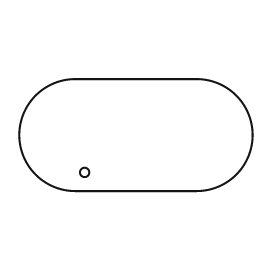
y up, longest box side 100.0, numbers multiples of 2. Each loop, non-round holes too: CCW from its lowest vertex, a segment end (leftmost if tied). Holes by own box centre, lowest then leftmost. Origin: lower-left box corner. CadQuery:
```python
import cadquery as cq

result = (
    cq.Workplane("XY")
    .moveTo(24.0, 0.0)
    .lineTo(76.0, 0.0)
    .threePointArc((100.0, 24.0), (76.0, 48.0))
    .lineTo(24.0, 48.0)
    .threePointArc((0.0, 24.0), (24.0, 0.0))
    .close()
    .moveTo(28.0, 8.0)
    .circle(2.0)
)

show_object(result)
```